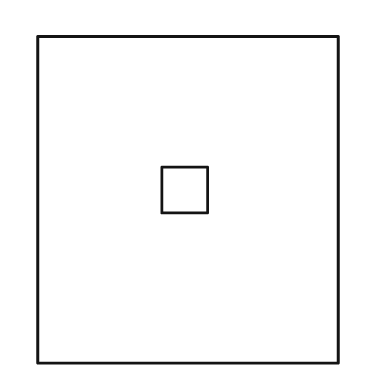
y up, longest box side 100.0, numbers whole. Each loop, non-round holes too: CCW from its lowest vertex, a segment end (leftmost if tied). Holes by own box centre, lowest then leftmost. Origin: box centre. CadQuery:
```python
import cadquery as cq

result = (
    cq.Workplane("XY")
    .moveTo(-46.0, -50.0)
    .lineTo(46.0, -50.0)
    .lineTo(46.0, 50.0)
    .lineTo(-46.0, 50.0)
    .close()
    .moveTo(-8.0, -4.0)
    .lineTo(6.0, -4.0)
    .lineTo(6.0, 10.0)
    .lineTo(-8.0, 10.0)
    .close()
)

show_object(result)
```